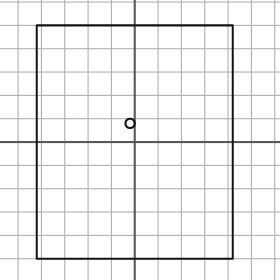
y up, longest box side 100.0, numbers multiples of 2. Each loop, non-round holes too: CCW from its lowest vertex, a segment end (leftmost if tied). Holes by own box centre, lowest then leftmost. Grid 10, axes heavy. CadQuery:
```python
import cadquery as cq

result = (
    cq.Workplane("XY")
    .moveTo(-42.0, -50.0)
    .lineTo(42.0, -50.0)
    .lineTo(42.0, 50.0)
    .lineTo(-42.0, 50.0)
    .close()
    .moveTo(-2.0, 8.0)
    .circle(2.0)
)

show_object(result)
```